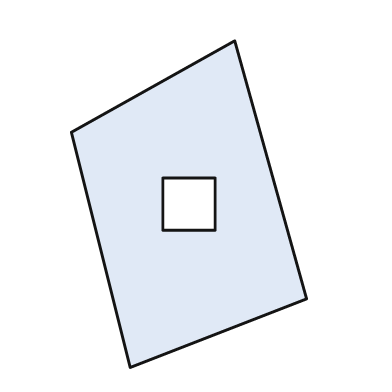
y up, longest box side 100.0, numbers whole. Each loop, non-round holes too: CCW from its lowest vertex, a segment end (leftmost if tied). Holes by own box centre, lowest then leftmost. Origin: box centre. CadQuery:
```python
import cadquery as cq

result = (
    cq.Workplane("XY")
    .moveTo(-18.0, -50.0)
    .lineTo(36.0, -29.0)
    .lineTo(14.0, 50.0)
    .lineTo(-36.0, 22.0)
    .close()
    .moveTo(-8.0, -8.0)
    .lineTo(8.0, -8.0)
    .lineTo(8.0, 8.0)
    .lineTo(-8.0, 8.0)
    .close()
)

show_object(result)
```